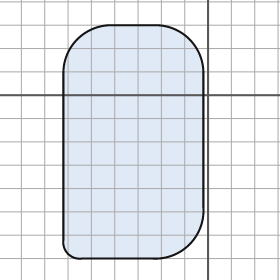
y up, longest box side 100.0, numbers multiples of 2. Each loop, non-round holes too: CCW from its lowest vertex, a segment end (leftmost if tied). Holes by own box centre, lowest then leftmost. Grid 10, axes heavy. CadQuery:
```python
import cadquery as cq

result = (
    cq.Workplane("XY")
    .moveTo(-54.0, -70.0)
    .lineTo(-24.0, -70.0)
    .threePointArc((-8.0, -64.0), (-2.0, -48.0))
    .lineTo(-2.0, 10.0)
    .threePointArc((-8.0, 24.0), (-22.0, 30.0))
    .lineTo(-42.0, 30.0)
    .threePointArc((-56.0, 24.0), (-62.0, 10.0))
    .lineTo(-62.0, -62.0)
    .threePointArc((-60.0, -68.0), (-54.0, -70.0))
    .close()
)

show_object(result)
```